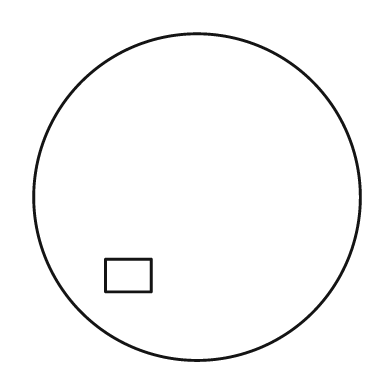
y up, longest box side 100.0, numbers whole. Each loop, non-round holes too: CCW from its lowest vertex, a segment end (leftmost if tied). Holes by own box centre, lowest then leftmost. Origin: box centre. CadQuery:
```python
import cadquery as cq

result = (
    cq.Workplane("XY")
    .moveTo(0.0, 0.0)
    .circle(50.0)
    .moveTo(-28.0, -29.0)
    .lineTo(-14.0, -29.0)
    .lineTo(-14.0, -19.0)
    .lineTo(-28.0, -19.0)
    .close()
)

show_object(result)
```